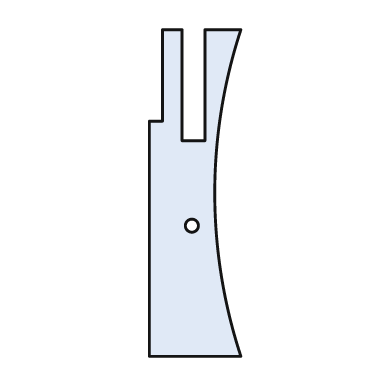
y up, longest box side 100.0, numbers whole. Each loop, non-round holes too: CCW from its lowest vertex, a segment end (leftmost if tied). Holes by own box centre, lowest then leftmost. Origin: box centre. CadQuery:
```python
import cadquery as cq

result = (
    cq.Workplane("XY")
    .moveTo(-14.0, -50.0)
    .lineTo(14.0, -50.0)
    .threePointArc((6.0, 0.0), (14.0, 50.0))
    .lineTo(3.0, 50.0)
    .lineTo(3.0, 16.0)
    .lineTo(-4.0, 16.0)
    .lineTo(-4.0, 50.0)
    .lineTo(-10.0, 50.0)
    .lineTo(-10.0, 22.0)
    .lineTo(-14.0, 22.0)
    .close()
    .moveTo(-1.0, -10.0)
    .circle(2.0)
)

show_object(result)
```